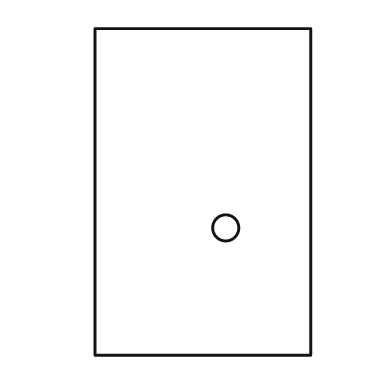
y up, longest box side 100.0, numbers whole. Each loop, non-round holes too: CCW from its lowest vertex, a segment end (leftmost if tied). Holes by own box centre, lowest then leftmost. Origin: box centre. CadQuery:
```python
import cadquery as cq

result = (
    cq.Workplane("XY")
    .moveTo(-33.0, -50.0)
    .lineTo(33.0, -50.0)
    .lineTo(33.0, 50.0)
    .lineTo(-33.0, 50.0)
    .close()
    .moveTo(7.0, -11.0)
    .circle(4.0)
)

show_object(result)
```